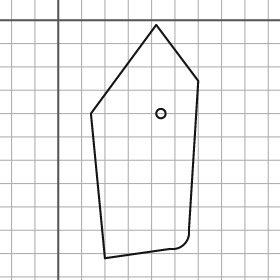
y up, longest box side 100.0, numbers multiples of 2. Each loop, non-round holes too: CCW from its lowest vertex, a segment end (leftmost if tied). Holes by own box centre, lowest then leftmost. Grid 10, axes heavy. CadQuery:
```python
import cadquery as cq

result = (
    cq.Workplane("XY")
    .moveTo(20.0, -102.0)
    .lineTo(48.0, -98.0)
    .threePointArc((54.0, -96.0), (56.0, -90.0))
    .lineTo(60.0, -26.0)
    .lineTo(42.0, -2.0)
    .lineTo(14.0, -40.0)
    .close()
    .moveTo(44.0, -40.0)
    .circle(2.0)
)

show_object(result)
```